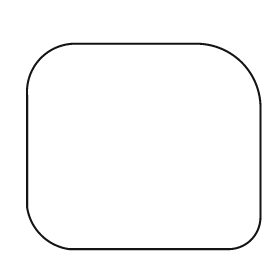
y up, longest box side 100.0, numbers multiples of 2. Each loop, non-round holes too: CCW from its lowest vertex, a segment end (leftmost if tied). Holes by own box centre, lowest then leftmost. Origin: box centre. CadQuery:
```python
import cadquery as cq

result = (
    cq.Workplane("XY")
    .moveTo(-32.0, -44.0)
    .lineTo(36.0, -44.0)
    .threePointArc((46.0, -40.0), (50.0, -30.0))
    .lineTo(50.0, 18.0)
    .threePointArc((42.0, 36.0), (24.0, 44.0))
    .lineTo(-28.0, 44.0)
    .threePointArc((-44.0, 38.0), (-50.0, 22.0))
    .lineTo(-50.0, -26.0)
    .threePointArc((-44.0, -38.0), (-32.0, -44.0))
    .close()
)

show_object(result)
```